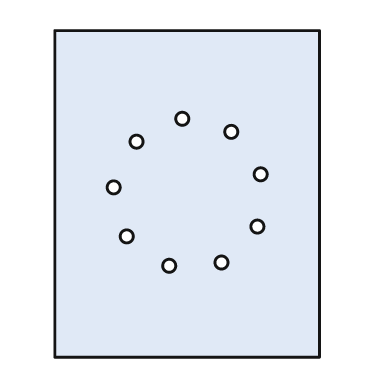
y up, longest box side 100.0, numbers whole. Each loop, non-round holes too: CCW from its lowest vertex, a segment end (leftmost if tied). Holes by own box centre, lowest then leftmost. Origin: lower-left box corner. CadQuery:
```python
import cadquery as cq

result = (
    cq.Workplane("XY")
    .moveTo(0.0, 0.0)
    .lineTo(81.0, 0.0)
    .lineTo(81.0, 100.0)
    .lineTo(0.0, 100.0)
    .close()
    .moveTo(35.0, 28.0)
    .circle(2.0)
    .moveTo(51.0, 29.0)
    .circle(2.0)
    .moveTo(22.0, 37.0)
    .circle(2.0)
    .moveTo(62.0, 40.0)
    .circle(2.0)
    .moveTo(18.0, 52.0)
    .circle(2.0)
    .moveTo(63.0, 56.0)
    .circle(2.0)
    .moveTo(25.0, 66.0)
    .circle(2.0)
    .moveTo(54.0, 69.0)
    .circle(2.0)
    .moveTo(39.0, 73.0)
    .circle(2.0)
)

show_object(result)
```